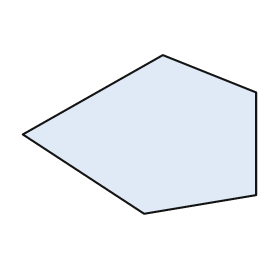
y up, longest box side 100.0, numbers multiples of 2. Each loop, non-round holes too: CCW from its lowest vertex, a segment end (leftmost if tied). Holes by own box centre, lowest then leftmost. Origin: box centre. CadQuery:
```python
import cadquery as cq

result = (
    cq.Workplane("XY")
    .moveTo(2.0, -34.0)
    .lineTo(50.0, -26.0)
    .lineTo(50.0, 18.0)
    .lineTo(10.0, 34.0)
    .lineTo(-50.0, 0.0)
    .close()
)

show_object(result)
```